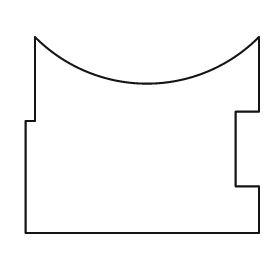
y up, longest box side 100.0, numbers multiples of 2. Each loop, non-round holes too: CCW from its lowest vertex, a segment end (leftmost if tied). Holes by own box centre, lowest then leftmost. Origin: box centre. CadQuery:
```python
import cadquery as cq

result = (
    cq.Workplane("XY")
    .moveTo(-50.0, -42.0)
    .lineTo(50.0, -42.0)
    .lineTo(50.0, -22.0)
    .lineTo(40.0, -22.0)
    .lineTo(40.0, 10.0)
    .lineTo(50.0, 10.0)
    .lineTo(50.0, 42.0)
    .threePointArc((2.0, 22.0), (-46.0, 42.0))
    .lineTo(-46.0, 6.0)
    .lineTo(-50.0, 6.0)
    .close()
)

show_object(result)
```